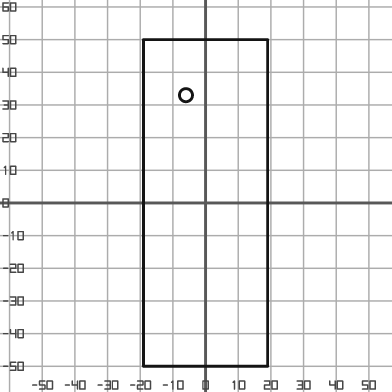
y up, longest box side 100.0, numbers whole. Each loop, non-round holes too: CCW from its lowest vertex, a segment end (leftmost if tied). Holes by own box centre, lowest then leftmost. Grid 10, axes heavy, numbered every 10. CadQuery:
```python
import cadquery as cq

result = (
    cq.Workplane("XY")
    .moveTo(-19.0, -50.0)
    .lineTo(19.0, -50.0)
    .lineTo(19.0, 50.0)
    .lineTo(-19.0, 50.0)
    .close()
    .moveTo(-6.0, 33.0)
    .circle(2.0)
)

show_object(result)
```